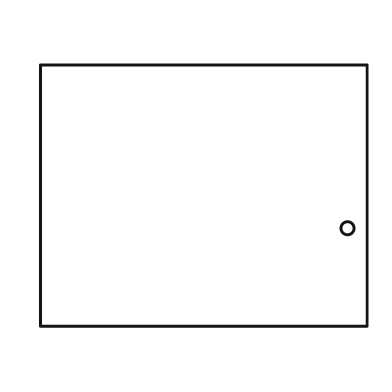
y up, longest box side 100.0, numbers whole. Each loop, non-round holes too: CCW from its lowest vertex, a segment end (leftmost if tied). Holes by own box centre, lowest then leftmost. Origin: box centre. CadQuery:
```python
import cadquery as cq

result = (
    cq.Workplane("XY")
    .moveTo(-50.0, -40.0)
    .lineTo(50.0, -40.0)
    .lineTo(50.0, 40.0)
    .lineTo(-50.0, 40.0)
    .close()
    .moveTo(44.0, -10.0)
    .circle(2.0)
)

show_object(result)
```